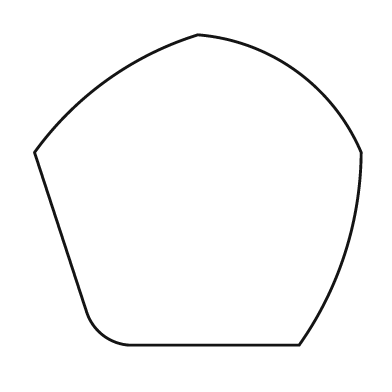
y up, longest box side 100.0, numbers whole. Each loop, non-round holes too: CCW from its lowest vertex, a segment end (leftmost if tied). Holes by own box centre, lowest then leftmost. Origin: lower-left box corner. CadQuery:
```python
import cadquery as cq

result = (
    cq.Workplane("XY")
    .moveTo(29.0, 0.0)
    .lineTo(81.0, 0.0)
    .threePointArc((95.0, 28.0), (100.0, 59.0))
    .threePointArc((80.0, 84.0), (50.0, 95.0))
    .threePointArc((22.0, 81.0), (0.0, 59.0))
    .lineTo(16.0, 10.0)
    .threePointArc((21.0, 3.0), (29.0, 0.0))
    .close()
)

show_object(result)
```